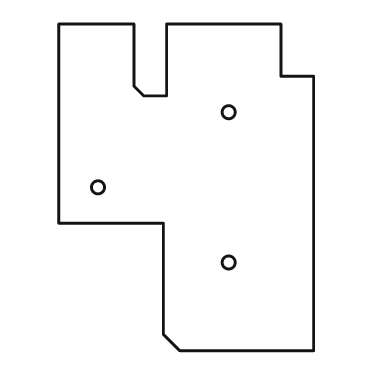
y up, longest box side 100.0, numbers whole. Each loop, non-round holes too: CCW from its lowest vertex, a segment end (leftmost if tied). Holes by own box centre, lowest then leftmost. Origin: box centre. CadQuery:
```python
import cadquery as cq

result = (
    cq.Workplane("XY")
    .moveTo(-2.0, -50.0)
    .lineTo(39.0, -50.0)
    .lineTo(39.0, 34.0)
    .lineTo(29.0, 34.0)
    .lineTo(29.0, 50.0)
    .lineTo(-6.0, 50.0)
    .lineTo(-6.0, 28.0)
    .lineTo(-13.0, 28.0)
    .lineTo(-16.0, 31.0)
    .lineTo(-16.0, 50.0)
    .lineTo(-39.0, 50.0)
    .lineTo(-39.0, -11.0)
    .lineTo(-7.0, -11.0)
    .lineTo(-7.0, -45.0)
    .close()
    .moveTo(13.0, -23.0)
    .circle(2.0)
    .moveTo(-27.0, 0.0)
    .circle(2.0)
    .moveTo(13.0, 23.0)
    .circle(2.0)
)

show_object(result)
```